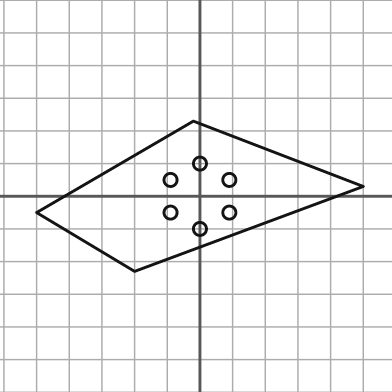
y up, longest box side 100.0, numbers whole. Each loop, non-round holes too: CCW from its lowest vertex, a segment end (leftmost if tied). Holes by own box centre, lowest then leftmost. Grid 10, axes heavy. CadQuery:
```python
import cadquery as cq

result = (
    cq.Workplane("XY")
    .moveTo(-20.0, -23.0)
    .lineTo(50.0, 3.0)
    .lineTo(-2.0, 23.0)
    .lineTo(-50.0, -5.0)
    .close()
    .moveTo(0.0, -10.0)
    .circle(2.0)
    .moveTo(-9.0, -5.0)
    .circle(2.0)
    .moveTo(9.0, -5.0)
    .circle(2.0)
    .moveTo(-9.0, 5.0)
    .circle(2.0)
    .moveTo(9.0, 5.0)
    .circle(2.0)
    .moveTo(0.0, 10.0)
    .circle(2.0)
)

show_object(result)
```